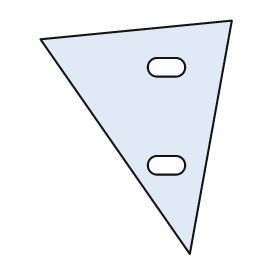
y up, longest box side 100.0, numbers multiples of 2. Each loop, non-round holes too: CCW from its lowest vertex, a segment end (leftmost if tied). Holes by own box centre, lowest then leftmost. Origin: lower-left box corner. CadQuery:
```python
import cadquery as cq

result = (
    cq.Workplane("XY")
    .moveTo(64.0, 0.0)
    .lineTo(82.0, 100.0)
    .lineTo(0.0, 92.0)
    .close()
    .moveTo(50.0, 34.0)
    .lineTo(58.0, 34.0)
    .threePointArc((62.0, 38.0), (58.0, 42.0))
    .lineTo(50.0, 42.0)
    .threePointArc((46.0, 38.0), (50.0, 34.0))
    .close()
    .moveTo(50.0, 76.0)
    .lineTo(58.0, 76.0)
    .threePointArc((62.0, 80.0), (58.0, 84.0))
    .lineTo(50.0, 84.0)
    .threePointArc((46.0, 80.0), (50.0, 76.0))
    .close()
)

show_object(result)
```